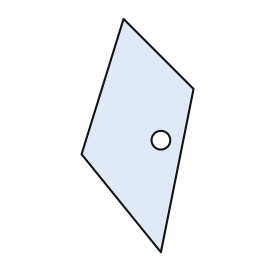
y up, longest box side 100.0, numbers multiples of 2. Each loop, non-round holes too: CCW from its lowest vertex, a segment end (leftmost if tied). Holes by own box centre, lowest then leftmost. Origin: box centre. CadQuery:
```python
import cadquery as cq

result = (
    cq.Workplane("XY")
    .moveTo(10.0, -50.0)
    .lineTo(24.0, 20.0)
    .lineTo(-6.0, 50.0)
    .lineTo(-24.0, -8.0)
    .close()
    .moveTo(10.0, -2.0)
    .circle(4.0)
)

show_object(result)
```